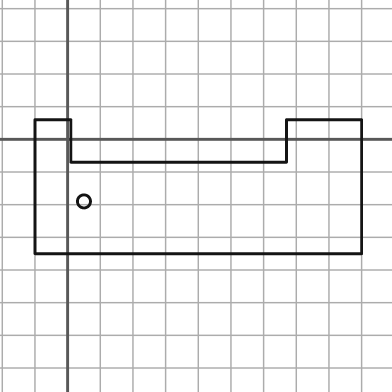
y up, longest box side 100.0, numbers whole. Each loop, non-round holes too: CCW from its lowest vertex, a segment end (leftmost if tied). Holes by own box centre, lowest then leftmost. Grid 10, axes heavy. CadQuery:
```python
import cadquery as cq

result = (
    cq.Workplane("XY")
    .moveTo(-10.0, -35.0)
    .lineTo(90.0, -35.0)
    .lineTo(90.0, 6.0)
    .lineTo(67.0, 6.0)
    .lineTo(67.0, -7.0)
    .lineTo(1.0, -7.0)
    .lineTo(1.0, 6.0)
    .lineTo(-10.0, 6.0)
    .close()
    .moveTo(5.0, -19.0)
    .circle(2.0)
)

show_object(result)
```